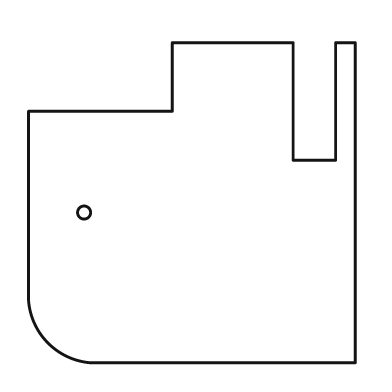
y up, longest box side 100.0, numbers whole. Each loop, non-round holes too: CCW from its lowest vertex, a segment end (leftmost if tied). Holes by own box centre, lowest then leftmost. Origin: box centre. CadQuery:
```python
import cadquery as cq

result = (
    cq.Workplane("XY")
    .moveTo(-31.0, -49.0)
    .lineTo(50.0, -49.0)
    .lineTo(50.0, 49.0)
    .lineTo(44.0, 49.0)
    .lineTo(44.0, 13.0)
    .lineTo(31.0, 13.0)
    .lineTo(31.0, 49.0)
    .lineTo(-6.0, 49.0)
    .lineTo(-6.0, 28.0)
    .lineTo(-50.0, 28.0)
    .lineTo(-50.0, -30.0)
    .threePointArc((-44.0, -43.0), (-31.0, -49.0))
    .close()
    .moveTo(-33.0, -3.0)
    .circle(2.0)
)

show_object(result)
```